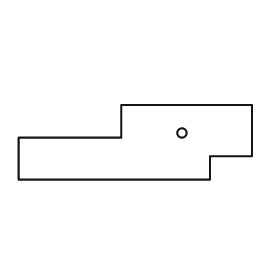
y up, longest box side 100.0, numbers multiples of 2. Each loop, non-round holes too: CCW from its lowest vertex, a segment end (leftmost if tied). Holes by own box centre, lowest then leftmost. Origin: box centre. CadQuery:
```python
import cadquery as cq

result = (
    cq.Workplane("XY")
    .moveTo(-50.0, -16.0)
    .lineTo(32.0, -16.0)
    .lineTo(32.0, -6.0)
    .lineTo(50.0, -6.0)
    .lineTo(50.0, 16.0)
    .lineTo(-6.0, 16.0)
    .lineTo(-6.0, 2.0)
    .lineTo(-50.0, 2.0)
    .close()
    .moveTo(20.0, 4.0)
    .circle(2.0)
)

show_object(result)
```